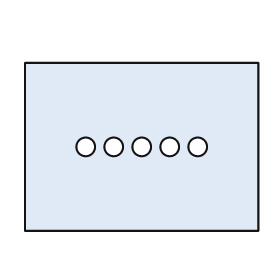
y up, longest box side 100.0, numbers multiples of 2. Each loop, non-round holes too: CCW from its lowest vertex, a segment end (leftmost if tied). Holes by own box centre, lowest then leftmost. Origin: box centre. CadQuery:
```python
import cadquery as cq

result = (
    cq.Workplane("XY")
    .moveTo(-50.0, -36.0)
    .lineTo(50.0, -36.0)
    .lineTo(50.0, 36.0)
    .lineTo(-50.0, 36.0)
    .close()
    .moveTo(-24.0, 0.0)
    .circle(4.0)
    .moveTo(-12.0, 0.0)
    .circle(4.0)
    .moveTo(0.0, 0.0)
    .circle(4.0)
    .moveTo(12.0, 0.0)
    .circle(4.0)
    .moveTo(24.0, 0.0)
    .circle(4.0)
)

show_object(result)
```